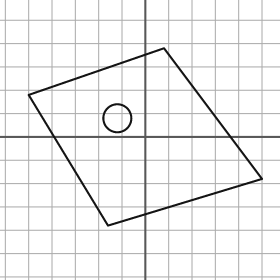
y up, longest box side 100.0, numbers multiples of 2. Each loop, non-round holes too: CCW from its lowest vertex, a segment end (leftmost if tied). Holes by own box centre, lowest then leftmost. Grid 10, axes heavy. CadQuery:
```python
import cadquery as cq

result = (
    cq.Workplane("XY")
    .moveTo(-16.0, -38.0)
    .lineTo(50.0, -18.0)
    .lineTo(8.0, 38.0)
    .lineTo(-50.0, 18.0)
    .close()
    .moveTo(-12.0, 8.0)
    .circle(6.0)
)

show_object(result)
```